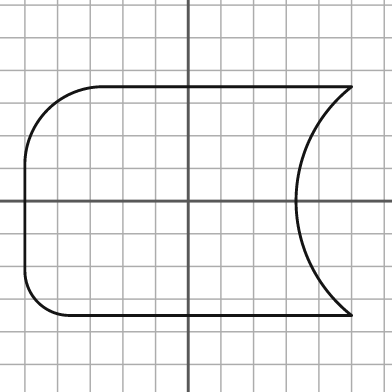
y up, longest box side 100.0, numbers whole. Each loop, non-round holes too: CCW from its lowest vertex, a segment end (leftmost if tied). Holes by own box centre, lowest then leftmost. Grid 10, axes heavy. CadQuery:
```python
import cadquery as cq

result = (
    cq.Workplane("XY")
    .moveTo(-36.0, -35.0)
    .lineTo(50.0, -35.0)
    .threePointArc((33.0, 0.0), (50.0, 35.0))
    .lineTo(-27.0, 35.0)
    .threePointArc((-43.0, 28.0), (-50.0, 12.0))
    .lineTo(-50.0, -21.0)
    .threePointArc((-46.0, -31.0), (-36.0, -35.0))
    .close()
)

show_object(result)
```